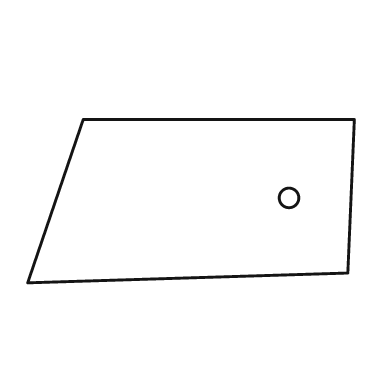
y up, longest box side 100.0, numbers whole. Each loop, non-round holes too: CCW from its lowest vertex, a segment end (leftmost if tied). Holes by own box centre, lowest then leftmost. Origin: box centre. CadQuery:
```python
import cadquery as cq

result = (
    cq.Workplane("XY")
    .moveTo(-50.0, -25.0)
    .lineTo(48.0, -22.0)
    .lineTo(50.0, 25.0)
    .lineTo(-33.0, 25.0)
    .close()
    .moveTo(30.0, 1.0)
    .circle(3.0)
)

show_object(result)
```